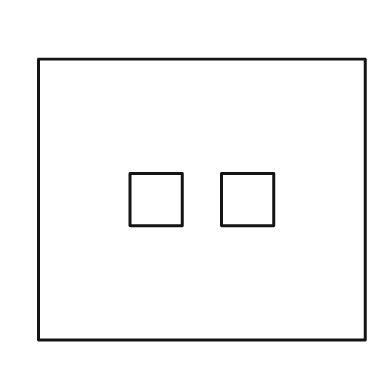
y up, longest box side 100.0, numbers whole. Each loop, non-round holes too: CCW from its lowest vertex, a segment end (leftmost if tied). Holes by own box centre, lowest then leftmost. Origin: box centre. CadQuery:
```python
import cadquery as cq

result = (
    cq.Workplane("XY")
    .moveTo(-50.0, -43.0)
    .lineTo(50.0, -43.0)
    .lineTo(50.0, 43.0)
    .lineTo(-50.0, 43.0)
    .close()
    .moveTo(-22.0, -8.0)
    .lineTo(-6.0, -8.0)
    .lineTo(-6.0, 8.0)
    .lineTo(-22.0, 8.0)
    .close()
    .moveTo(6.0, -8.0)
    .lineTo(22.0, -8.0)
    .lineTo(22.0, 8.0)
    .lineTo(6.0, 8.0)
    .close()
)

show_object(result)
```